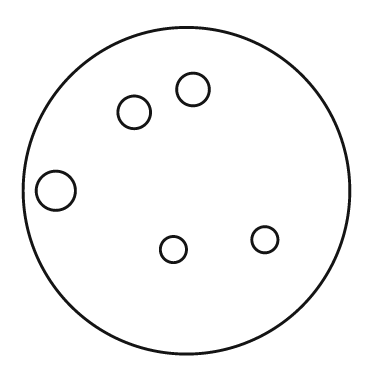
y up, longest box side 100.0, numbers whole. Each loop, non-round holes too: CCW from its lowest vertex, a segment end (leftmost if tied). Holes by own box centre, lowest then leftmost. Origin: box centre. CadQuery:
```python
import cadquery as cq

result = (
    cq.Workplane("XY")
    .moveTo(0.0, 0.0)
    .circle(50.0)
    .moveTo(-4.0, -18.0)
    .circle(4.0)
    .moveTo(24.0, -15.0)
    .circle(4.0)
    .moveTo(-40.0, 0.0)
    .circle(6.0)
    .moveTo(-16.0, 24.0)
    .circle(5.0)
    .moveTo(2.0, 31.0)
    .circle(5.0)
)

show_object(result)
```